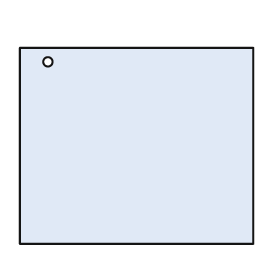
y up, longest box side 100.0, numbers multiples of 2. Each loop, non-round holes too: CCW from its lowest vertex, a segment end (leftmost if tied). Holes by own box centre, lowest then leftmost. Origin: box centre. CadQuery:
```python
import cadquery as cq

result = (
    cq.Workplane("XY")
    .moveTo(-50.0, -42.0)
    .lineTo(50.0, -42.0)
    .lineTo(50.0, 42.0)
    .lineTo(-50.0, 42.0)
    .close()
    .moveTo(-38.0, 36.0)
    .circle(2.0)
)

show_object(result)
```